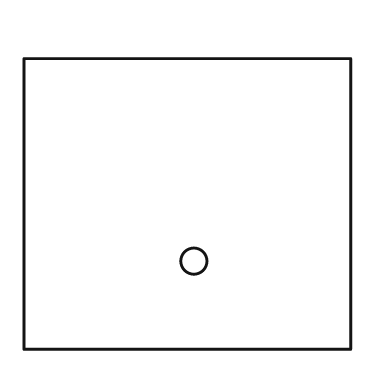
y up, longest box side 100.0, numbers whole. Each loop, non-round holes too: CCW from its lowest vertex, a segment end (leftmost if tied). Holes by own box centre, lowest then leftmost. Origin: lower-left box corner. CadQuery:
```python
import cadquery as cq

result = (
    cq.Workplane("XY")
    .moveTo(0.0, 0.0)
    .lineTo(100.0, 0.0)
    .lineTo(100.0, 89.0)
    .lineTo(0.0, 89.0)
    .close()
    .moveTo(52.0, 27.0)
    .circle(4.0)
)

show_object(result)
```